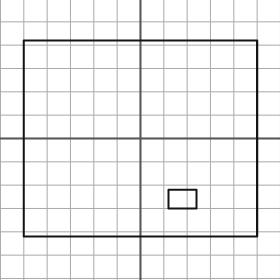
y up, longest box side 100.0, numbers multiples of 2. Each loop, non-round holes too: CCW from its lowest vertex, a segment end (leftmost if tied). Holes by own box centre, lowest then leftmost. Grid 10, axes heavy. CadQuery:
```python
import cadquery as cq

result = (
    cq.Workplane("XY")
    .moveTo(-50.0, -42.0)
    .lineTo(50.0, -42.0)
    .lineTo(50.0, 42.0)
    .lineTo(-50.0, 42.0)
    .close()
    .moveTo(12.0, -30.0)
    .lineTo(24.0, -30.0)
    .lineTo(24.0, -22.0)
    .lineTo(12.0, -22.0)
    .close()
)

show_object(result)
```